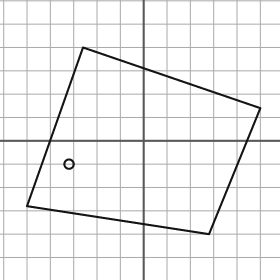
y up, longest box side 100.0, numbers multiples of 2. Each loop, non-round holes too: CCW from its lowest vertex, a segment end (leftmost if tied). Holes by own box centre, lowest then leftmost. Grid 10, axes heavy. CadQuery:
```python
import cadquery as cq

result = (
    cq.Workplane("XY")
    .moveTo(28.0, -40.0)
    .lineTo(50.0, 14.0)
    .lineTo(-26.0, 40.0)
    .lineTo(-50.0, -28.0)
    .close()
    .moveTo(-32.0, -10.0)
    .circle(2.0)
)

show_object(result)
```